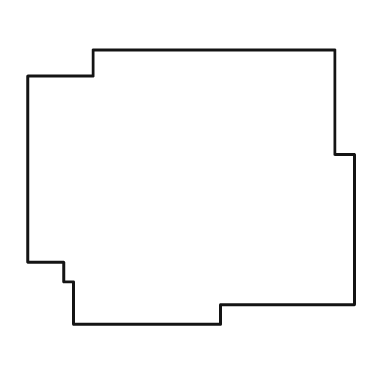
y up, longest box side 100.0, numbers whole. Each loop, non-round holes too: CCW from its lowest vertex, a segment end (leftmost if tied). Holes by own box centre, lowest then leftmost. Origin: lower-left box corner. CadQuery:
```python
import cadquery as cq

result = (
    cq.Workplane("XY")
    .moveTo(14.0, 0.0)
    .lineTo(59.0, 0.0)
    .lineTo(59.0, 6.0)
    .lineTo(100.0, 6.0)
    .lineTo(100.0, 52.0)
    .lineTo(94.0, 52.0)
    .lineTo(94.0, 84.0)
    .lineTo(20.0, 84.0)
    .lineTo(20.0, 76.0)
    .lineTo(0.0, 76.0)
    .lineTo(0.0, 19.0)
    .lineTo(11.0, 19.0)
    .lineTo(11.0, 13.0)
    .lineTo(14.0, 13.0)
    .close()
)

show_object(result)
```